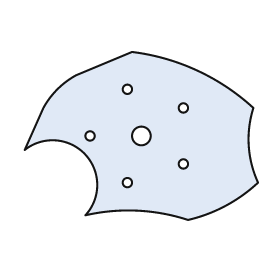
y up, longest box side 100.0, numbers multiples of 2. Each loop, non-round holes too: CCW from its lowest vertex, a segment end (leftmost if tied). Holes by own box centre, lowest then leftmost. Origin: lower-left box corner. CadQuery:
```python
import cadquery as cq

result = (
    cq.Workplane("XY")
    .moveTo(70.0, 0.0)
    .threePointArc((86.0, 6.0), (100.0, 16.0))
    .threePointArc((96.0, 32.0), (98.0, 48.0))
    .threePointArc((74.0, 64.0), (46.0, 72.0))
    .lineTo(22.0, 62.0)
    .threePointArc((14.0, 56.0), (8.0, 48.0))
    .lineTo(0.0, 30.0)
    .threePointArc((26.0, 28.0), (26.0, 2.0))
    .threePointArc((48.0, 4.0), (70.0, 0.0))
    .close()
    .moveTo(44.0, 16.0)
    .circle(2.0)
    .moveTo(68.0, 24.0)
    .circle(2.0)
    .moveTo(28.0, 36.0)
    .circle(2.0)
    .moveTo(50.0, 36.0)
    .circle(4.0)
    .moveTo(68.0, 48.0)
    .circle(2.0)
    .moveTo(44.0, 56.0)
    .circle(2.0)
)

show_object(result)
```